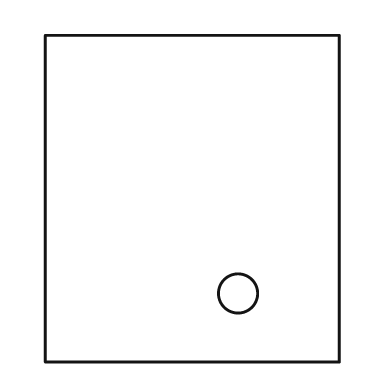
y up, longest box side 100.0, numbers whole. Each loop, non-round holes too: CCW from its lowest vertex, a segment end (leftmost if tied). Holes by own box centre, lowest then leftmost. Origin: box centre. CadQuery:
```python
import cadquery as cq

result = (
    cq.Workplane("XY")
    .moveTo(-45.0, -50.0)
    .lineTo(45.0, -50.0)
    .lineTo(45.0, 50.0)
    .lineTo(-45.0, 50.0)
    .close()
    .moveTo(14.0, -29.0)
    .circle(6.0)
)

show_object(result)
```